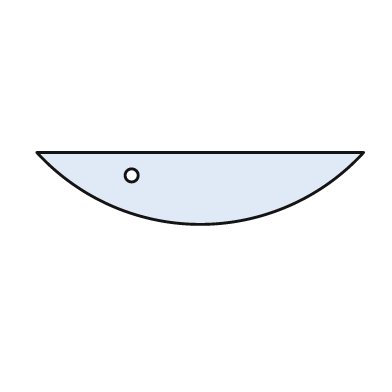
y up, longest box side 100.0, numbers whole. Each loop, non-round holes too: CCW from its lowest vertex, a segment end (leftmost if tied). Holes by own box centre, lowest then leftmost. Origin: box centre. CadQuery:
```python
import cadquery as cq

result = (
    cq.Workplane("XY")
    .moveTo(-50.0, 11.0)
    .threePointArc((0.0, -11.0), (50.0, 11.0))
    .close()
    .moveTo(-21.0, 4.0)
    .circle(2.0)
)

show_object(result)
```